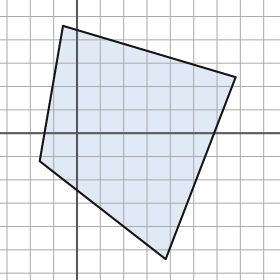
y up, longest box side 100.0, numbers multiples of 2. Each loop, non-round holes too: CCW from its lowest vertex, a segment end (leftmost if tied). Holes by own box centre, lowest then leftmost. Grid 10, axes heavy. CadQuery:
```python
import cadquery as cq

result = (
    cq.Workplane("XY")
    .moveTo(38.0, -54.0)
    .lineTo(68.0, 24.0)
    .lineTo(-6.0, 46.0)
    .lineTo(-16.0, -12.0)
    .close()
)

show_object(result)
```